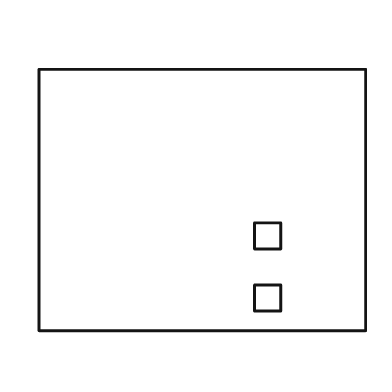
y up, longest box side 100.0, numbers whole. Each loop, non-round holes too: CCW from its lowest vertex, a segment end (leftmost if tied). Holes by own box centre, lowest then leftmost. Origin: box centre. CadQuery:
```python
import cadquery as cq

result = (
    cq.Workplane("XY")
    .moveTo(-50.0, -40.0)
    .lineTo(50.0, -40.0)
    .lineTo(50.0, 40.0)
    .lineTo(-50.0, 40.0)
    .close()
    .moveTo(16.0, -34.0)
    .lineTo(24.0, -34.0)
    .lineTo(24.0, -26.0)
    .lineTo(16.0, -26.0)
    .close()
    .moveTo(16.0, -15.0)
    .lineTo(24.0, -15.0)
    .lineTo(24.0, -7.0)
    .lineTo(16.0, -7.0)
    .close()
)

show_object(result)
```